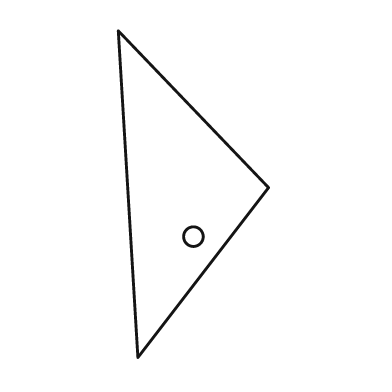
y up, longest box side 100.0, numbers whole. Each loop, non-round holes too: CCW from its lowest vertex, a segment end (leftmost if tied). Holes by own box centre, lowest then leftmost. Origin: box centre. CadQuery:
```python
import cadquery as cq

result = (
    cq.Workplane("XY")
    .moveTo(-17.0, -50.0)
    .lineTo(23.0, 2.0)
    .lineTo(-23.0, 50.0)
    .close()
    .moveTo(0.0, -13.0)
    .circle(3.0)
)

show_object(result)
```